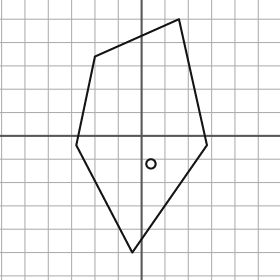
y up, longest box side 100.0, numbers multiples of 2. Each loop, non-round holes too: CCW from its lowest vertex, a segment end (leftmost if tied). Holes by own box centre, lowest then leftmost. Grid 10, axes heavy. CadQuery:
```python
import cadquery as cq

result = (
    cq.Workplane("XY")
    .moveTo(-4.0, -50.0)
    .lineTo(28.0, -4.0)
    .lineTo(16.0, 50.0)
    .lineTo(-20.0, 34.0)
    .lineTo(-28.0, -4.0)
    .close()
    .moveTo(4.0, -12.0)
    .circle(2.0)
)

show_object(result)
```